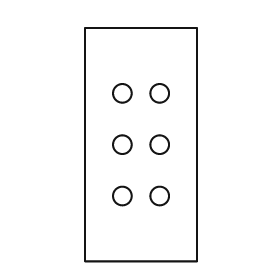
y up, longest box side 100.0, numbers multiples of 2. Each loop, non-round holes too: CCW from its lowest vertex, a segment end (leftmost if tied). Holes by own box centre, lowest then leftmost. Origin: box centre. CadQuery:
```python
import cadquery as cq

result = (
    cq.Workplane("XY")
    .moveTo(-24.0, -50.0)
    .lineTo(24.0, -50.0)
    .lineTo(24.0, 50.0)
    .lineTo(-24.0, 50.0)
    .close()
    .moveTo(-8.0, -22.0)
    .circle(4.0)
    .moveTo(8.0, -22.0)
    .circle(4.0)
    .moveTo(-8.0, 0.0)
    .circle(4.0)
    .moveTo(8.0, 0.0)
    .circle(4.0)
    .moveTo(-8.0, 22.0)
    .circle(4.0)
    .moveTo(8.0, 22.0)
    .circle(4.0)
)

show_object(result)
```